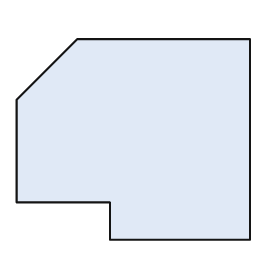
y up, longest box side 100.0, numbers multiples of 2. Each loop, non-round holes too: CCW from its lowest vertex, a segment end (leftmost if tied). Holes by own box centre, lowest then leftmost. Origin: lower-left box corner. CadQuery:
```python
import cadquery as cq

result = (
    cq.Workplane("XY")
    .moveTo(40.0, 0.0)
    .lineTo(100.0, 0.0)
    .lineTo(100.0, 86.0)
    .lineTo(26.0, 86.0)
    .lineTo(0.0, 60.0)
    .lineTo(0.0, 16.0)
    .lineTo(40.0, 16.0)
    .close()
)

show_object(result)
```